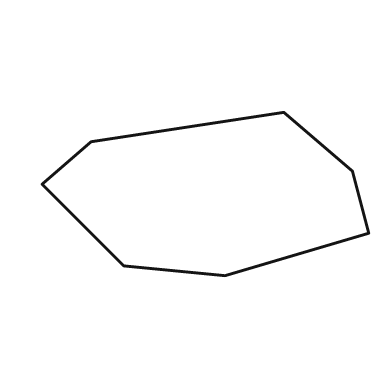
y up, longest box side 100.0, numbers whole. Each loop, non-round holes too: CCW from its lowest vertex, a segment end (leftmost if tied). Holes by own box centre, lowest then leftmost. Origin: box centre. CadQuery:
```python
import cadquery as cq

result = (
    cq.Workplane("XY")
    .moveTo(6.0, -25.0)
    .lineTo(50.0, -12.0)
    .lineTo(45.0, 7.0)
    .lineTo(24.0, 25.0)
    .lineTo(-35.0, 16.0)
    .lineTo(-50.0, 3.0)
    .lineTo(-25.0, -22.0)
    .close()
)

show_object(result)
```